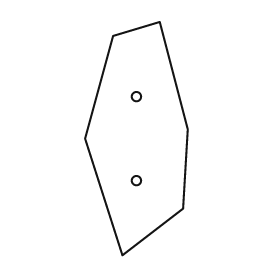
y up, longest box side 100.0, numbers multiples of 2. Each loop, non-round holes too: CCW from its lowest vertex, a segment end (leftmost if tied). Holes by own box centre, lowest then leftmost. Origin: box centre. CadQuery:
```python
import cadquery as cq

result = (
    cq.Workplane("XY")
    .moveTo(-6.0, -50.0)
    .lineTo(20.0, -30.0)
    .lineTo(22.0, 4.0)
    .lineTo(10.0, 50.0)
    .lineTo(-10.0, 44.0)
    .lineTo(-22.0, 0.0)
    .close()
    .moveTo(0.0, -18.0)
    .circle(2.0)
    .moveTo(0.0, 18.0)
    .circle(2.0)
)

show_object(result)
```